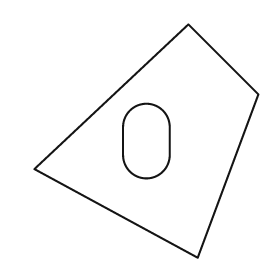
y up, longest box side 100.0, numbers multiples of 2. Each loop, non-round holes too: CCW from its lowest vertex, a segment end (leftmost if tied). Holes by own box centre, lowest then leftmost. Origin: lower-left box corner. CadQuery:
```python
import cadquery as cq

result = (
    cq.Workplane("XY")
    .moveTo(70.0, 0.0)
    .lineTo(96.0, 70.0)
    .lineTo(66.0, 100.0)
    .lineTo(0.0, 38.0)
    .close()
    .moveTo(38.0, 44.0)
    .threePointArc((48.0, 34.0), (58.0, 44.0))
    .lineTo(58.0, 56.0)
    .threePointArc((48.0, 66.0), (38.0, 56.0))
    .close()
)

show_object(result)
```